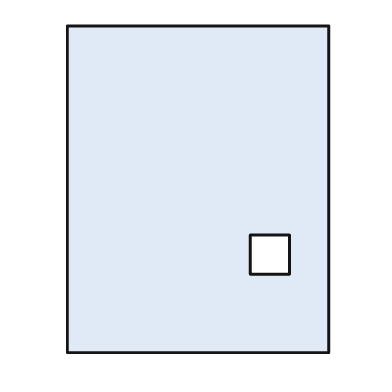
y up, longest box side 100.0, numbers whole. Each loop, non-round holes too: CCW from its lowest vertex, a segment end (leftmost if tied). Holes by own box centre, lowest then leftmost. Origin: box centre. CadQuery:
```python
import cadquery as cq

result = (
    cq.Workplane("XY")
    .moveTo(-40.0, -50.0)
    .lineTo(40.0, -50.0)
    .lineTo(40.0, 50.0)
    .lineTo(-40.0, 50.0)
    .close()
    .moveTo(16.0, -26.0)
    .lineTo(28.0, -26.0)
    .lineTo(28.0, -14.0)
    .lineTo(16.0, -14.0)
    .close()
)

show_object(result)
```